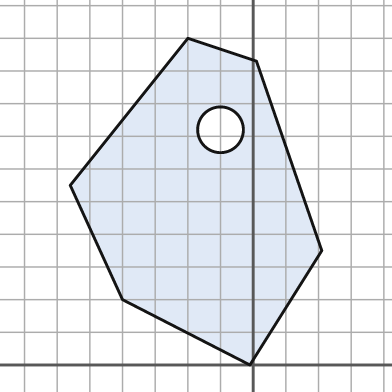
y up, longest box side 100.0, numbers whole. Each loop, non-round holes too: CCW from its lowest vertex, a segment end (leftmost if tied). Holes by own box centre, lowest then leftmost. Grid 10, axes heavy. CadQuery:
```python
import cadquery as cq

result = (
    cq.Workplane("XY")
    .moveTo(-1.0, 0.0)
    .lineTo(21.0, 35.0)
    .lineTo(1.0, 93.0)
    .lineTo(-20.0, 100.0)
    .lineTo(-56.0, 55.0)
    .lineTo(-40.0, 20.0)
    .close()
    .moveTo(-10.0, 72.0)
    .circle(7.0)
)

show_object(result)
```